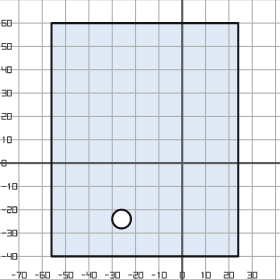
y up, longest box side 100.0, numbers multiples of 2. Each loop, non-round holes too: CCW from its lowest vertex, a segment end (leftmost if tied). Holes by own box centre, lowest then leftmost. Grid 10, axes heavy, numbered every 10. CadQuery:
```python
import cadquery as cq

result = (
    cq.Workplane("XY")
    .moveTo(-56.0, -40.0)
    .lineTo(24.0, -40.0)
    .lineTo(24.0, 60.0)
    .lineTo(-56.0, 60.0)
    .close()
    .moveTo(-26.0, -24.0)
    .circle(4.0)
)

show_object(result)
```